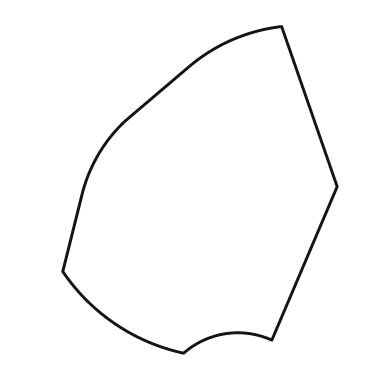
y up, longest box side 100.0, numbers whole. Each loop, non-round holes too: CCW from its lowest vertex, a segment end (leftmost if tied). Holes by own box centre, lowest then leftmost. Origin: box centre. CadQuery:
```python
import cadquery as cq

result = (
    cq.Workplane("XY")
    .moveTo(-5.0, -50.0)
    .threePointArc((8.0, -44.0), (22.0, -46.0))
    .lineTo(42.0, 1.0)
    .lineTo(25.0, 50.0)
    .threePointArc((10.0, 46.0), (-3.0, 38.0))
    .lineTo(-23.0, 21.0)
    .threePointArc((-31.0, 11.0), (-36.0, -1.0))
    .lineTo(-42.0, -25.0)
    .threePointArc((-26.0, -41.0), (-5.0, -50.0))
    .close()
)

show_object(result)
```